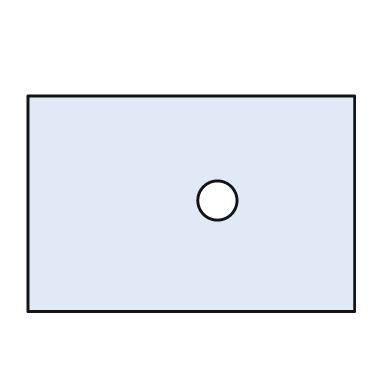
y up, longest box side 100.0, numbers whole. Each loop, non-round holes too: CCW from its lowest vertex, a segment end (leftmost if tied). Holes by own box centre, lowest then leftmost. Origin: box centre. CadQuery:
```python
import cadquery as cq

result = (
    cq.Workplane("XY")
    .moveTo(-50.0, -33.0)
    .lineTo(50.0, -33.0)
    .lineTo(50.0, 33.0)
    .lineTo(-50.0, 33.0)
    .close()
    .moveTo(8.0, 1.0)
    .circle(6.0)
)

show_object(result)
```